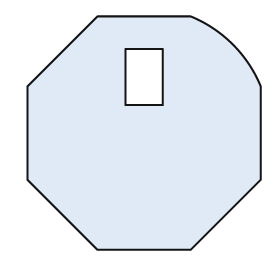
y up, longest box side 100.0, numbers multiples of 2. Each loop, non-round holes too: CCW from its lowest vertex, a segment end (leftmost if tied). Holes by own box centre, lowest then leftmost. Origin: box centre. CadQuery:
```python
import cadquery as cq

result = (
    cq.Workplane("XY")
    .moveTo(-20.0, -50.0)
    .lineTo(20.0, -50.0)
    .lineTo(50.0, -20.0)
    .lineTo(50.0, 20.0)
    .threePointArc((38.0, 38.0), (20.0, 50.0))
    .lineTo(-20.0, 50.0)
    .lineTo(-50.0, 20.0)
    .lineTo(-50.0, -20.0)
    .close()
    .moveTo(-8.0, 12.0)
    .lineTo(8.0, 12.0)
    .lineTo(8.0, 36.0)
    .lineTo(-8.0, 36.0)
    .close()
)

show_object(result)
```